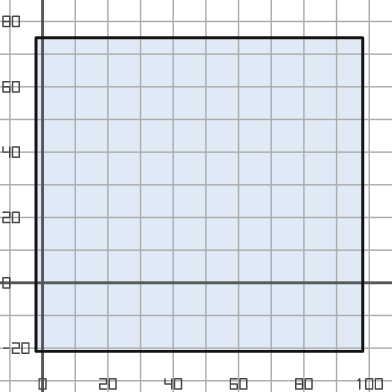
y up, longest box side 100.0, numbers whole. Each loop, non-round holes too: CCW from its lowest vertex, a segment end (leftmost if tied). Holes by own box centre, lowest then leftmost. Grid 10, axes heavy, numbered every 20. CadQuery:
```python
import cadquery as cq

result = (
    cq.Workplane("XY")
    .moveTo(-2.0, -21.0)
    .lineTo(98.0, -21.0)
    .lineTo(98.0, 75.0)
    .lineTo(-2.0, 75.0)
    .close()
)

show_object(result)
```